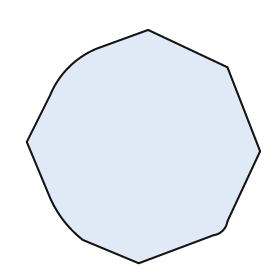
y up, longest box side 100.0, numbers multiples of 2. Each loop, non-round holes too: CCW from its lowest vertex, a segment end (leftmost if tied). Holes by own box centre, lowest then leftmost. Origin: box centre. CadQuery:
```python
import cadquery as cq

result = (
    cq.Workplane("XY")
    .moveTo(-2.0, -50.0)
    .lineTo(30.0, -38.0)
    .threePointArc((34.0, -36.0), (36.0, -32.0))
    .lineTo(50.0, -2.0)
    .lineTo(36.0, 34.0)
    .lineTo(2.0, 50.0)
    .lineTo(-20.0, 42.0)
    .threePointArc((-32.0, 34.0), (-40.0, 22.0))
    .lineTo(-50.0, 2.0)
    .lineTo(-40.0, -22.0)
    .threePointArc((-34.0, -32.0), (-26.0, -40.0))
    .close()
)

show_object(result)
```